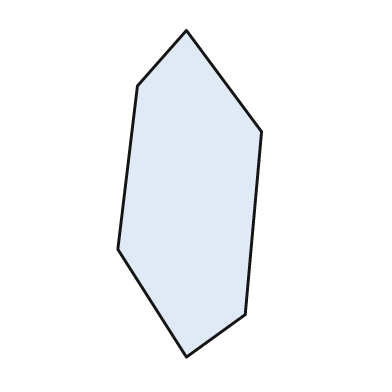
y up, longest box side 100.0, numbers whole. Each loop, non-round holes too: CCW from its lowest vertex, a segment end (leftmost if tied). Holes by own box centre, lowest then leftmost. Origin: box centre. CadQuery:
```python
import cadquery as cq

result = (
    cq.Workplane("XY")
    .moveTo(-1.0, -50.0)
    .lineTo(17.0, -37.0)
    .lineTo(22.0, 19.0)
    .lineTo(-1.0, 50.0)
    .lineTo(-16.0, 33.0)
    .lineTo(-22.0, -17.0)
    .close()
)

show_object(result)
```